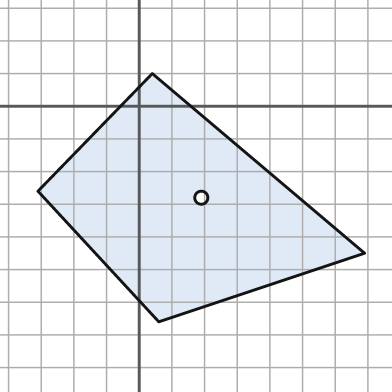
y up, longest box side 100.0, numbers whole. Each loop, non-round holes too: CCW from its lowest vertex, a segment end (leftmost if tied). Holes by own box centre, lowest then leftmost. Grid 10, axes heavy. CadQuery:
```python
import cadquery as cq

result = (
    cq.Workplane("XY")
    .moveTo(6.0, -66.0)
    .lineTo(69.0, -45.0)
    .lineTo(4.0, 10.0)
    .lineTo(-31.0, -26.0)
    .close()
    .moveTo(19.0, -28.0)
    .circle(2.0)
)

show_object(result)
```